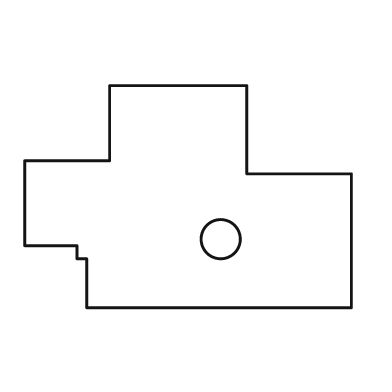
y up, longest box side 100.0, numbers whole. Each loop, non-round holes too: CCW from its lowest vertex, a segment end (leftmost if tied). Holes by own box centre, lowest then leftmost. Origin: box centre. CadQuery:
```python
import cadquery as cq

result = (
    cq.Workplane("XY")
    .moveTo(-31.0, -34.0)
    .lineTo(50.0, -34.0)
    .lineTo(50.0, 7.0)
    .lineTo(18.0, 7.0)
    .lineTo(18.0, 34.0)
    .lineTo(-24.0, 34.0)
    .lineTo(-24.0, 11.0)
    .lineTo(-50.0, 11.0)
    .lineTo(-50.0, -15.0)
    .lineTo(-34.0, -15.0)
    .lineTo(-34.0, -19.0)
    .lineTo(-31.0, -19.0)
    .close()
    .moveTo(10.0, -13.0)
    .circle(6.0)
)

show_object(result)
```